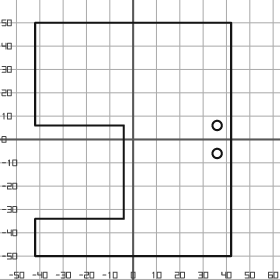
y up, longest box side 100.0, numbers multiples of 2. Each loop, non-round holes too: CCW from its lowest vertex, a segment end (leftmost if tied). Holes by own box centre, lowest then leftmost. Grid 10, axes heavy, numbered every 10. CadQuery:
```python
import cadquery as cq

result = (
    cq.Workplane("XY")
    .moveTo(-42.0, -50.0)
    .lineTo(42.0, -50.0)
    .lineTo(42.0, 50.0)
    .lineTo(-42.0, 50.0)
    .lineTo(-42.0, 6.0)
    .lineTo(-4.0, 6.0)
    .lineTo(-4.0, -34.0)
    .lineTo(-42.0, -34.0)
    .close()
    .moveTo(36.0, -6.0)
    .circle(2.0)
    .moveTo(36.0, 6.0)
    .circle(2.0)
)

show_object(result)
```